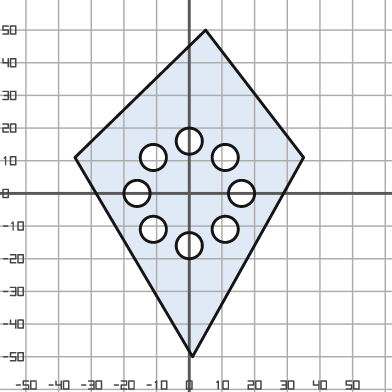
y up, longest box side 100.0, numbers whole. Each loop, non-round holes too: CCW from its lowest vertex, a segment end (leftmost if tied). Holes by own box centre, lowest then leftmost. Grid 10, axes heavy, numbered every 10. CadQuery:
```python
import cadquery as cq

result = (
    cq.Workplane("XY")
    .moveTo(1.0, -50.0)
    .lineTo(35.0, 11.0)
    .lineTo(5.0, 50.0)
    .lineTo(-35.0, 11.0)
    .close()
    .moveTo(0.0, -16.0)
    .circle(4.0)
    .moveTo(-11.0, -11.0)
    .circle(4.0)
    .moveTo(11.0, -11.0)
    .circle(4.0)
    .moveTo(-16.0, 0.0)
    .circle(4.0)
    .moveTo(16.0, 0.0)
    .circle(4.0)
    .moveTo(-11.0, 11.0)
    .circle(4.0)
    .moveTo(11.0, 11.0)
    .circle(4.0)
    .moveTo(0.0, 16.0)
    .circle(4.0)
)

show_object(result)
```